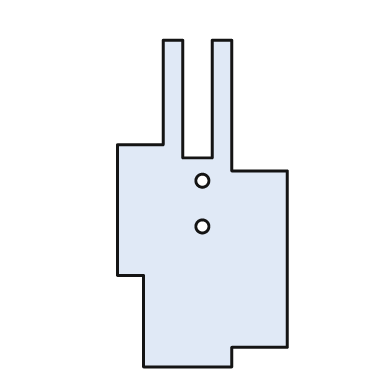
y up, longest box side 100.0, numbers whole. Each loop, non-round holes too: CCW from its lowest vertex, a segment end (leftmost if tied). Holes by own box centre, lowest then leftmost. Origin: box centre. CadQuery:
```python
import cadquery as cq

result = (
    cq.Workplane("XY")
    .moveTo(-18.0, -50.0)
    .lineTo(9.0, -50.0)
    .lineTo(9.0, -44.0)
    .lineTo(26.0, -44.0)
    .lineTo(26.0, 10.0)
    .lineTo(9.0, 10.0)
    .lineTo(9.0, 50.0)
    .lineTo(3.0, 50.0)
    .lineTo(3.0, 14.0)
    .lineTo(-6.0, 14.0)
    .lineTo(-6.0, 50.0)
    .lineTo(-12.0, 50.0)
    .lineTo(-12.0, 18.0)
    .lineTo(-26.0, 18.0)
    .lineTo(-26.0, -22.0)
    .lineTo(-18.0, -22.0)
    .close()
    .moveTo(0.0, -7.0)
    .circle(2.0)
    .moveTo(0.0, 7.0)
    .circle(2.0)
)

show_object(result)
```